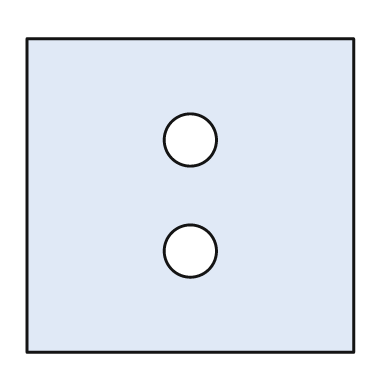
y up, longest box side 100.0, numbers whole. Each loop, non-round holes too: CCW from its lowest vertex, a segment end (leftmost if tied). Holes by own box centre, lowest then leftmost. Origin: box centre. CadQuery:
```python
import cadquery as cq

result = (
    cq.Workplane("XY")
    .moveTo(-50.0, -48.0)
    .lineTo(50.0, -48.0)
    .lineTo(50.0, 48.0)
    .lineTo(-50.0, 48.0)
    .close()
    .moveTo(0.0, -17.0)
    .circle(8.0)
    .moveTo(0.0, 17.0)
    .circle(8.0)
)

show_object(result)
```